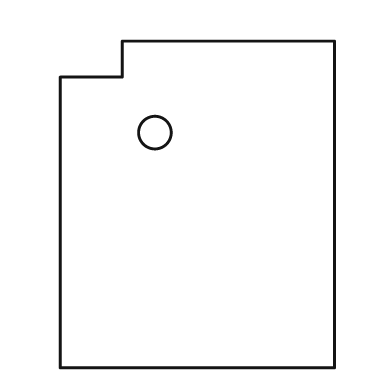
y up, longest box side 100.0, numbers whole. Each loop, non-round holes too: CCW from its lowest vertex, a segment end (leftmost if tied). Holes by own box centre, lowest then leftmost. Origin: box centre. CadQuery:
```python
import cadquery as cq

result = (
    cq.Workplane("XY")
    .moveTo(-42.0, -50.0)
    .lineTo(42.0, -50.0)
    .lineTo(42.0, 50.0)
    .lineTo(-23.0, 50.0)
    .lineTo(-23.0, 39.0)
    .lineTo(-42.0, 39.0)
    .close()
    .moveTo(-13.0, 22.0)
    .circle(5.0)
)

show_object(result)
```